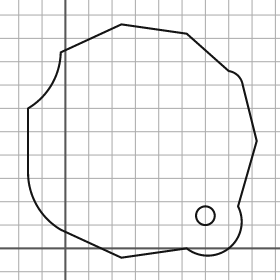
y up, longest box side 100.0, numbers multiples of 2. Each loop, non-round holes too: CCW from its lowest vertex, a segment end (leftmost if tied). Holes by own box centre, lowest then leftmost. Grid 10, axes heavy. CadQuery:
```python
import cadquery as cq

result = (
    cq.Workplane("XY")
    .moveTo(24.0, -4.0)
    .lineTo(52.0, 0.0)
    .threePointArc((70.0, 0.0), (74.0, 18.0))
    .lineTo(82.0, 46.0)
    .lineTo(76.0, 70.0)
    .threePointArc((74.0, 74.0), (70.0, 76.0))
    .lineTo(52.0, 92.0)
    .lineTo(24.0, 96.0)
    .lineTo(-2.0, 84.0)
    .threePointArc((-6.0, 70.0), (-16.0, 60.0))
    .lineTo(-16.0, 32.0)
    .threePointArc((-12.0, 18.0), (-2.0, 8.0))
    .close()
    .moveTo(60.0, 14.0)
    .circle(4.0)
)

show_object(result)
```